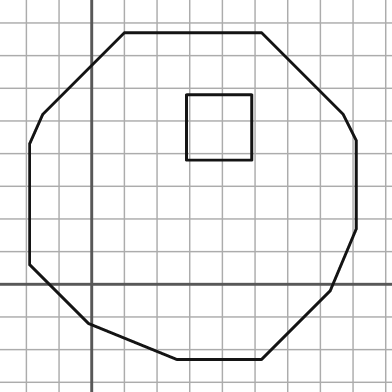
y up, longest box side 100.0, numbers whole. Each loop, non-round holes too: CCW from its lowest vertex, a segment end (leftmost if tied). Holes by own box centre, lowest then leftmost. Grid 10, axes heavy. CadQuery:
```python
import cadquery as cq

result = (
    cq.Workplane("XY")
    .moveTo(26.0, -23.0)
    .lineTo(52.0, -23.0)
    .lineTo(73.0, -2.0)
    .lineTo(81.0, 17.0)
    .lineTo(81.0, 44.0)
    .lineTo(77.0, 52.0)
    .lineTo(52.0, 77.0)
    .lineTo(10.0, 77.0)
    .lineTo(-15.0, 52.0)
    .lineTo(-19.0, 43.0)
    .lineTo(-19.0, 6.0)
    .lineTo(-1.0, -12.0)
    .close()
    .moveTo(29.0, 38.0)
    .lineTo(49.0, 38.0)
    .lineTo(49.0, 58.0)
    .lineTo(29.0, 58.0)
    .close()
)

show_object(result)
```